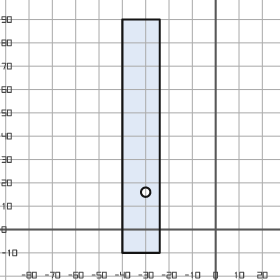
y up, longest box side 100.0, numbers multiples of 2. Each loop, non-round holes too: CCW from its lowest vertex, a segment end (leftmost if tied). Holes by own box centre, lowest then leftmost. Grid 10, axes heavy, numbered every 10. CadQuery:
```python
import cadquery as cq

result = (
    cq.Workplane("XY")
    .moveTo(-40.0, -10.0)
    .lineTo(-24.0, -10.0)
    .lineTo(-24.0, 90.0)
    .lineTo(-40.0, 90.0)
    .close()
    .moveTo(-30.0, 16.0)
    .circle(2.0)
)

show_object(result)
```